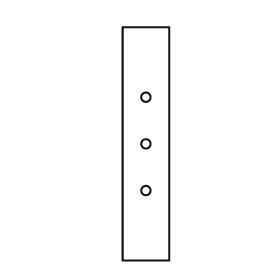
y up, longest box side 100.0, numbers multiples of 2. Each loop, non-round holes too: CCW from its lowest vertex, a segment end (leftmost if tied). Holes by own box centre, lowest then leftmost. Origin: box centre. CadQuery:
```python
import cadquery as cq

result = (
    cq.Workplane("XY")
    .moveTo(-10.0, -50.0)
    .lineTo(10.0, -50.0)
    .lineTo(10.0, 50.0)
    .lineTo(-10.0, 50.0)
    .close()
    .moveTo(0.0, -20.0)
    .circle(2.0)
    .moveTo(0.0, 0.0)
    .circle(2.0)
    .moveTo(0.0, 20.0)
    .circle(2.0)
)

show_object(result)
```